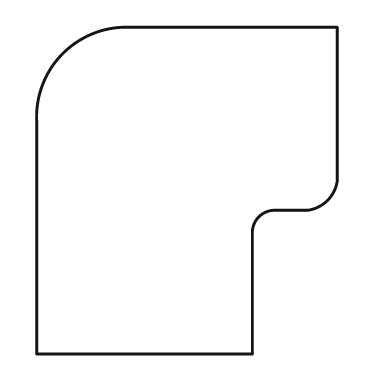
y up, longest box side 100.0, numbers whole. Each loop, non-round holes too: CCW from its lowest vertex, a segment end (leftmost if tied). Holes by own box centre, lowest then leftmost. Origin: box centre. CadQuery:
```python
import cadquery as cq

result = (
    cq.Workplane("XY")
    .moveTo(-46.0, -50.0)
    .lineTo(20.0, -50.0)
    .lineTo(20.0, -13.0)
    .threePointArc((22.0, -8.0), (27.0, -6.0))
    .lineTo(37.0, -6.0)
    .threePointArc((43.0, -3.0), (46.0, 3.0))
    .lineTo(46.0, 50.0)
    .lineTo(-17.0, 50.0)
    .threePointArc((-38.0, 42.0), (-46.0, 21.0))
    .close()
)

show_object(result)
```